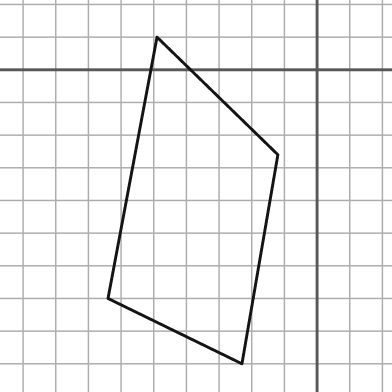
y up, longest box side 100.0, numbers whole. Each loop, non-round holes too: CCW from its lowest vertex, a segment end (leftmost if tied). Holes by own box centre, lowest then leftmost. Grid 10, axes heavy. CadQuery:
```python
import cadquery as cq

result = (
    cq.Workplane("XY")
    .moveTo(-23.0, -90.0)
    .lineTo(-12.0, -26.0)
    .lineTo(-49.0, 10.0)
    .lineTo(-64.0, -70.0)
    .close()
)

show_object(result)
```